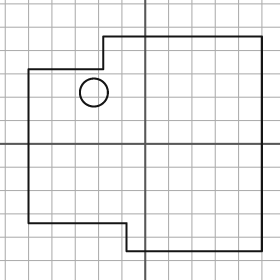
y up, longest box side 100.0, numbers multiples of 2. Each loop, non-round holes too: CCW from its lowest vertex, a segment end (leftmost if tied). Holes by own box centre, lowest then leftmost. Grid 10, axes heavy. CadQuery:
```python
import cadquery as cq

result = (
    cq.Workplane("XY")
    .moveTo(-8.0, -46.0)
    .lineTo(50.0, -46.0)
    .lineTo(50.0, 46.0)
    .lineTo(-18.0, 46.0)
    .lineTo(-18.0, 32.0)
    .lineTo(-50.0, 32.0)
    .lineTo(-50.0, -34.0)
    .lineTo(-8.0, -34.0)
    .close()
    .moveTo(-22.0, 22.0)
    .circle(6.0)
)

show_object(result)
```